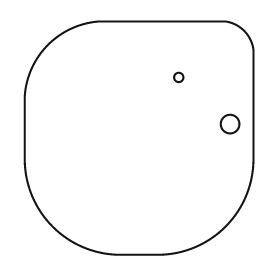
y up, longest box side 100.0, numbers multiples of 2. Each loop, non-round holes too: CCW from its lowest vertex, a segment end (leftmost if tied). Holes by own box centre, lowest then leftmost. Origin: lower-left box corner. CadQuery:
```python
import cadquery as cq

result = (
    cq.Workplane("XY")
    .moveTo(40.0, 0.0)
    .lineTo(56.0, 0.0)
    .threePointArc((86.0, 12.0), (98.0, 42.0))
    .lineTo(98.0, 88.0)
    .threePointArc((94.0, 96.0), (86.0, 100.0))
    .lineTo(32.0, 100.0)
    .threePointArc((10.0, 90.0), (0.0, 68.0))
    .lineTo(0.0, 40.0)
    .threePointArc((12.0, 12.0), (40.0, 0.0))
    .close()
    .moveTo(88.0, 56.0)
    .circle(4.0)
    .moveTo(66.0, 76.0)
    .circle(2.0)
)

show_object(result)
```